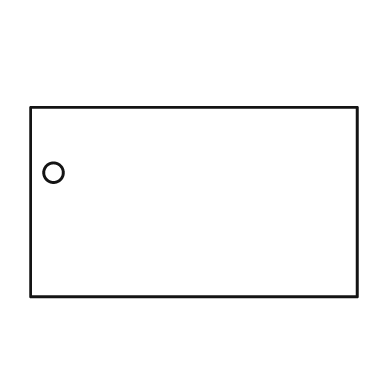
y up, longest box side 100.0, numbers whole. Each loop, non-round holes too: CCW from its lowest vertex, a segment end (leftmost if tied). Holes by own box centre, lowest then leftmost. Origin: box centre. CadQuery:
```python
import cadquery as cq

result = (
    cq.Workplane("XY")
    .moveTo(-50.0, -29.0)
    .lineTo(50.0, -29.0)
    .lineTo(50.0, 29.0)
    .lineTo(-50.0, 29.0)
    .close()
    .moveTo(-43.0, 9.0)
    .circle(3.0)
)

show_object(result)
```